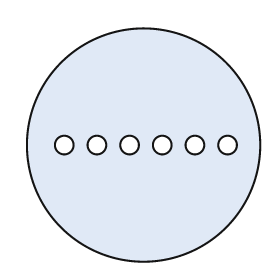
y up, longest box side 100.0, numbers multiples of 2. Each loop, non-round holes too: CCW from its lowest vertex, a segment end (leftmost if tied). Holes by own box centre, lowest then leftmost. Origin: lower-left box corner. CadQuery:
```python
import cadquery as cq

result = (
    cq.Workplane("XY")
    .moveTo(50.0, 50.0)
    .circle(50.0)
    .moveTo(16.0, 50.0)
    .circle(4.0)
    .moveTo(30.0, 50.0)
    .circle(4.0)
    .moveTo(44.0, 50.0)
    .circle(4.0)
    .moveTo(58.0, 50.0)
    .circle(4.0)
    .moveTo(72.0, 50.0)
    .circle(4.0)
    .moveTo(86.0, 50.0)
    .circle(4.0)
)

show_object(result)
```